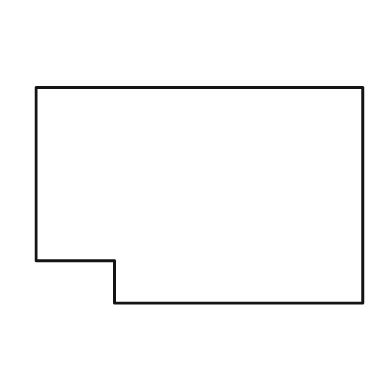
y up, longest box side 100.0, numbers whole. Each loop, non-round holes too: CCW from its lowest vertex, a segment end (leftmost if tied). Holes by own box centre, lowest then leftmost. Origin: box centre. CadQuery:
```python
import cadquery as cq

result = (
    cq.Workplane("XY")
    .moveTo(-26.0, -33.0)
    .lineTo(50.0, -33.0)
    .lineTo(50.0, 33.0)
    .lineTo(-50.0, 33.0)
    .lineTo(-50.0, -20.0)
    .lineTo(-26.0, -20.0)
    .close()
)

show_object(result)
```